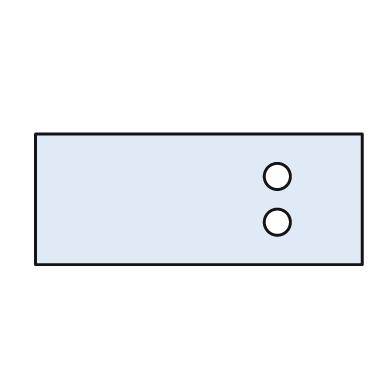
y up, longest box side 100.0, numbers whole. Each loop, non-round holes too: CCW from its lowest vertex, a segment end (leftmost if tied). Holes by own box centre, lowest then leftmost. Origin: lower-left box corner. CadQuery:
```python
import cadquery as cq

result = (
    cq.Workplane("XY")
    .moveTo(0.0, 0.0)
    .lineTo(100.0, 0.0)
    .lineTo(100.0, 40.0)
    .lineTo(0.0, 40.0)
    .close()
    .moveTo(74.0, 13.0)
    .circle(4.0)
    .moveTo(74.0, 27.0)
    .circle(4.0)
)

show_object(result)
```